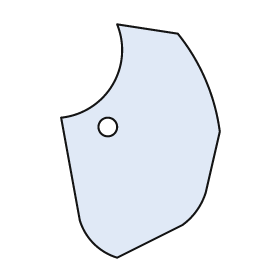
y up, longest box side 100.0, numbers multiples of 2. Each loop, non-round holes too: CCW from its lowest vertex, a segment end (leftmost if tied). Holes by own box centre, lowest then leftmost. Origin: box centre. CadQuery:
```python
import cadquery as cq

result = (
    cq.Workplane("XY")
    .moveTo(-10.0, -50.0)
    .lineTo(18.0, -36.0)
    .threePointArc((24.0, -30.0), (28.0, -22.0))
    .lineTo(34.0, 4.0)
    .threePointArc((28.0, 26.0), (16.0, 46.0))
    .lineTo(-10.0, 50.0)
    .threePointArc((-12.0, 24.0), (-34.0, 10.0))
    .lineTo(-26.0, -34.0)
    .threePointArc((-20.0, -44.0), (-10.0, -50.0))
    .close()
    .moveTo(-14.0, 6.0)
    .circle(4.0)
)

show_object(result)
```